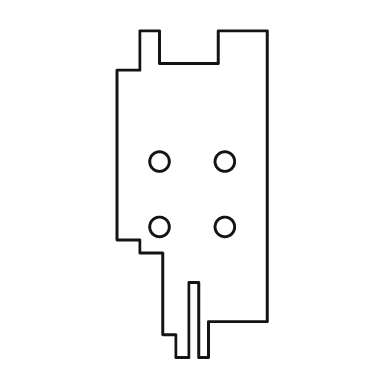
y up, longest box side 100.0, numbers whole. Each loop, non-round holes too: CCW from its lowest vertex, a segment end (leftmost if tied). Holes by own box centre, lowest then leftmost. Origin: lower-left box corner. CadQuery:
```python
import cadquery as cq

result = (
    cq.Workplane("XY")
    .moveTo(18.0, 0.0)
    .lineTo(22.0, 0.0)
    .lineTo(22.0, 23.0)
    .lineTo(25.0, 23.0)
    .lineTo(25.0, 0.0)
    .lineTo(28.0, 0.0)
    .lineTo(28.0, 11.0)
    .lineTo(46.0, 11.0)
    .lineTo(46.0, 100.0)
    .lineTo(31.0, 100.0)
    .lineTo(31.0, 90.0)
    .lineTo(13.0, 90.0)
    .lineTo(13.0, 100.0)
    .lineTo(7.0, 100.0)
    .lineTo(7.0, 88.0)
    .lineTo(0.0, 88.0)
    .lineTo(0.0, 36.0)
    .lineTo(7.0, 36.0)
    .lineTo(7.0, 32.0)
    .lineTo(14.0, 32.0)
    .lineTo(14.0, 7.0)
    .lineTo(18.0, 7.0)
    .close()
    .moveTo(13.0, 40.0)
    .circle(3.0)
    .moveTo(33.0, 40.0)
    .circle(3.0)
    .moveTo(13.0, 60.0)
    .circle(3.0)
    .moveTo(33.0, 60.0)
    .circle(3.0)
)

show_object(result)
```